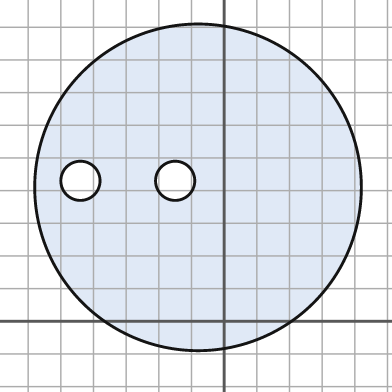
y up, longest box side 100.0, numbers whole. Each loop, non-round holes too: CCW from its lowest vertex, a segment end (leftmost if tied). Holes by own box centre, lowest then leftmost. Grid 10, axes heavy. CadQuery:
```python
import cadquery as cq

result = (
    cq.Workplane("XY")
    .moveTo(-8.0, 41.0)
    .circle(50.0)
    .moveTo(-44.0, 43.0)
    .circle(6.0)
    .moveTo(-15.0, 43.0)
    .circle(6.0)
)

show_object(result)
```